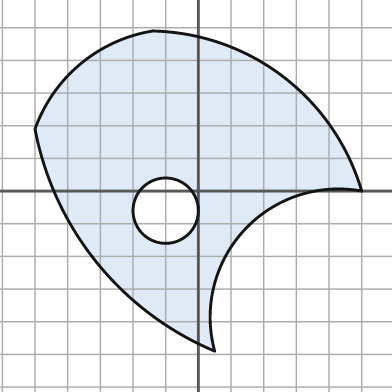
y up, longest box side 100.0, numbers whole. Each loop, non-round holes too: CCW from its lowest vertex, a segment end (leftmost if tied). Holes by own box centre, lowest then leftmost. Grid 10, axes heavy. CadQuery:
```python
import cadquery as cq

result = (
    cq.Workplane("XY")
    .moveTo(5.0, -49.0)
    .threePointArc((14.0, -12.0), (50.0, 0.0))
    .threePointArc((26.0, 35.0), (-14.0, 49.0))
    .threePointArc((-36.0, 39.0), (-50.0, 19.0))
    .threePointArc((-31.0, -22.0), (5.0, -49.0))
    .close()
    .moveTo(-10.0, -6.0)
    .circle(10.0)
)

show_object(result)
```